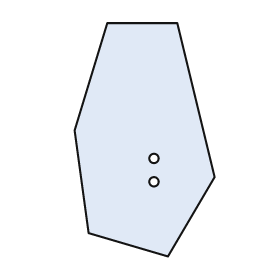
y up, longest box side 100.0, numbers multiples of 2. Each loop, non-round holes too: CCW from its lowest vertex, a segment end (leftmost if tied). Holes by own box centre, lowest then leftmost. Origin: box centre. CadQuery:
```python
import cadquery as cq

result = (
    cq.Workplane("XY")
    .moveTo(10.0, -50.0)
    .lineTo(30.0, -16.0)
    .lineTo(14.0, 50.0)
    .lineTo(-16.0, 50.0)
    .lineTo(-30.0, 4.0)
    .lineTo(-24.0, -40.0)
    .close()
    .moveTo(4.0, -18.0)
    .circle(2.0)
    .moveTo(4.0, -8.0)
    .circle(2.0)
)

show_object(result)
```